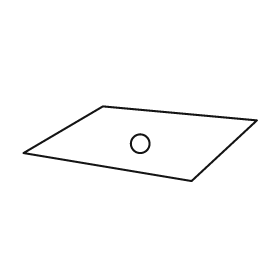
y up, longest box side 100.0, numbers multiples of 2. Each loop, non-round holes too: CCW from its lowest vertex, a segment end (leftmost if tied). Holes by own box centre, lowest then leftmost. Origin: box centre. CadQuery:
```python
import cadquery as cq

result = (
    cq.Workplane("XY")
    .moveTo(22.0, -16.0)
    .lineTo(50.0, 10.0)
    .lineTo(-16.0, 16.0)
    .lineTo(-50.0, -4.0)
    .close()
    .moveTo(0.0, 0.0)
    .circle(4.0)
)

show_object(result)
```